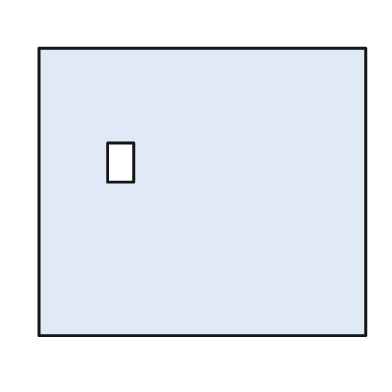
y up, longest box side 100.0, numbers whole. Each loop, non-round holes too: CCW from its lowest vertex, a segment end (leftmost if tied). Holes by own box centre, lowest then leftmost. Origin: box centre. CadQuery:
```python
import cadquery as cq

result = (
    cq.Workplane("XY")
    .moveTo(-50.0, -44.0)
    .lineTo(50.0, -44.0)
    .lineTo(50.0, 44.0)
    .lineTo(-50.0, 44.0)
    .close()
    .moveTo(-29.0, 3.0)
    .lineTo(-21.0, 3.0)
    .lineTo(-21.0, 15.0)
    .lineTo(-29.0, 15.0)
    .close()
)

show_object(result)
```